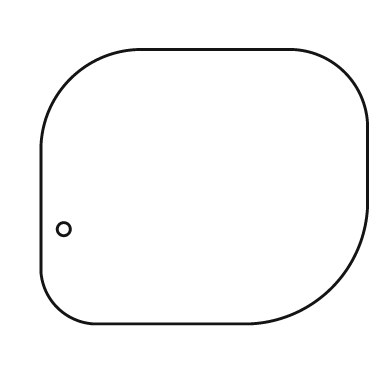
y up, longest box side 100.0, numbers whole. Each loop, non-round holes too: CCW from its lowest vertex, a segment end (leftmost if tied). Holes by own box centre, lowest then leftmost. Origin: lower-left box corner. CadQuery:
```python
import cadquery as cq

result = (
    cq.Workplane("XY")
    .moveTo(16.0, 0.0)
    .lineTo(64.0, 0.0)
    .threePointArc((89.0, 11.0), (100.0, 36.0))
    .lineTo(100.0, 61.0)
    .threePointArc((93.0, 77.0), (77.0, 84.0))
    .lineTo(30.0, 84.0)
    .threePointArc((9.0, 75.0), (0.0, 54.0))
    .lineTo(0.0, 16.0)
    .threePointArc((5.0, 5.0), (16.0, 0.0))
    .close()
    .moveTo(7.0, 29.0)
    .circle(2.0)
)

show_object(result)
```